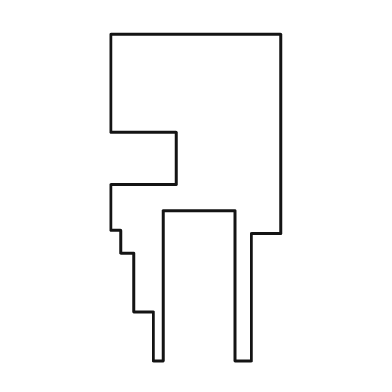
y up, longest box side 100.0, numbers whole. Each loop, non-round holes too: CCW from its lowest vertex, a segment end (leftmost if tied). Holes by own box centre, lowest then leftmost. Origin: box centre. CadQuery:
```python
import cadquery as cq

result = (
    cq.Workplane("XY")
    .moveTo(-13.0, -50.0)
    .lineTo(-10.0, -50.0)
    .lineTo(-10.0, -4.0)
    .lineTo(12.0, -4.0)
    .lineTo(12.0, -50.0)
    .lineTo(17.0, -50.0)
    .lineTo(17.0, -11.0)
    .lineTo(26.0, -11.0)
    .lineTo(26.0, 50.0)
    .lineTo(-26.0, 50.0)
    .lineTo(-26.0, 20.0)
    .lineTo(-6.0, 20.0)
    .lineTo(-6.0, 4.0)
    .lineTo(-26.0, 4.0)
    .lineTo(-26.0, -10.0)
    .lineTo(-23.0, -10.0)
    .lineTo(-23.0, -17.0)
    .lineTo(-19.0, -17.0)
    .lineTo(-19.0, -35.0)
    .lineTo(-13.0, -35.0)
    .close()
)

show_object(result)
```